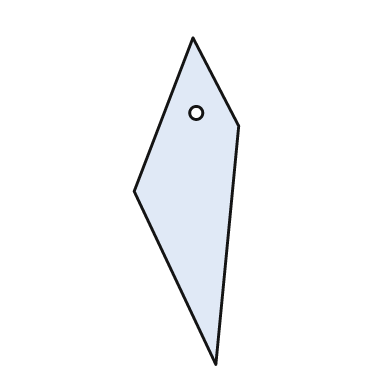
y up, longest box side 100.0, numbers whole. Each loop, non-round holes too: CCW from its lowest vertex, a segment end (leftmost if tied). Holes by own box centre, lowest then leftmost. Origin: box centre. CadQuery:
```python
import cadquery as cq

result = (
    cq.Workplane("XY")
    .moveTo(9.0, -50.0)
    .lineTo(16.0, 23.0)
    .lineTo(2.0, 50.0)
    .lineTo(-16.0, 3.0)
    .close()
    .moveTo(3.0, 27.0)
    .circle(2.0)
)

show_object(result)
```